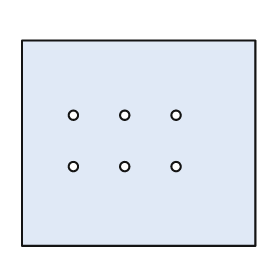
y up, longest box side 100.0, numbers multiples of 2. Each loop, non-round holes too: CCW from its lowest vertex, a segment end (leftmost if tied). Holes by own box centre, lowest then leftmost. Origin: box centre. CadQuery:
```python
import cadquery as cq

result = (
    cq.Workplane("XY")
    .moveTo(-50.0, -44.0)
    .lineTo(50.0, -44.0)
    .lineTo(50.0, 44.0)
    .lineTo(-50.0, 44.0)
    .close()
    .moveTo(-28.0, -10.0)
    .circle(2.0)
    .moveTo(-6.0, -10.0)
    .circle(2.0)
    .moveTo(16.0, -10.0)
    .circle(2.0)
    .moveTo(-28.0, 12.0)
    .circle(2.0)
    .moveTo(-6.0, 12.0)
    .circle(2.0)
    .moveTo(16.0, 12.0)
    .circle(2.0)
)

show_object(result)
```